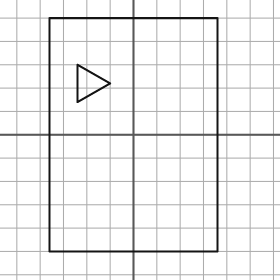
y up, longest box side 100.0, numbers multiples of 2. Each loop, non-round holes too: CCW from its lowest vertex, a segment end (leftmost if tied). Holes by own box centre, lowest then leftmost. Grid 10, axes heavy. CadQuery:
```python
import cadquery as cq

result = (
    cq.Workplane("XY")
    .moveTo(-36.0, -50.0)
    .lineTo(36.0, -50.0)
    .lineTo(36.0, 50.0)
    .lineTo(-36.0, 50.0)
    .close()
    .moveTo(-24.0, 14.0)
    .lineTo(-10.0, 22.0)
    .lineTo(-24.0, 30.0)
    .close()
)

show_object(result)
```